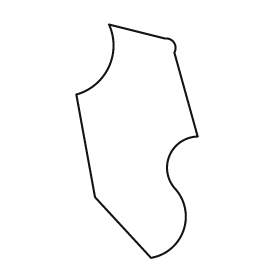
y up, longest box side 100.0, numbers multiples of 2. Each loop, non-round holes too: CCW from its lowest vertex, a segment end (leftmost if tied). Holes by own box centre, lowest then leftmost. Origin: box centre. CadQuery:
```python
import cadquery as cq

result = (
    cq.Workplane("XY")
    .moveTo(6.0, -50.0)
    .threePointArc((20.0, -38.0), (16.0, -20.0))
    .threePointArc((14.0, -6.0), (26.0, 2.0))
    .lineTo(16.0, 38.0)
    .threePointArc((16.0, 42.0), (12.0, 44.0))
    .lineTo(-12.0, 50.0)
    .threePointArc((-12.0, 32.0), (-26.0, 20.0))
    .lineTo(-18.0, -24.0)
    .close()
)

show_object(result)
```